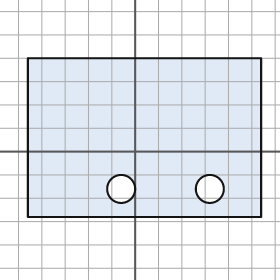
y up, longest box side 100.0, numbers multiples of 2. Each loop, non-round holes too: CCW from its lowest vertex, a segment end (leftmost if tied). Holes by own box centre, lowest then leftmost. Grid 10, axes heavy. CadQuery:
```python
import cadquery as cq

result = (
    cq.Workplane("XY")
    .moveTo(-46.0, -28.0)
    .lineTo(54.0, -28.0)
    .lineTo(54.0, 40.0)
    .lineTo(-46.0, 40.0)
    .close()
    .moveTo(-6.0, -16.0)
    .circle(6.0)
    .moveTo(32.0, -16.0)
    .circle(6.0)
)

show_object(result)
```